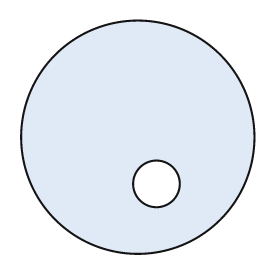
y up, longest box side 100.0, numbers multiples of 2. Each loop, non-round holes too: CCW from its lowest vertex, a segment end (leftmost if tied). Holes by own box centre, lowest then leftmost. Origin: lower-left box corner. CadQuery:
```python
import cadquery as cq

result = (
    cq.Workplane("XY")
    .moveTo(50.0, 50.0)
    .circle(50.0)
    .moveTo(58.0, 30.0)
    .circle(10.0)
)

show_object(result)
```